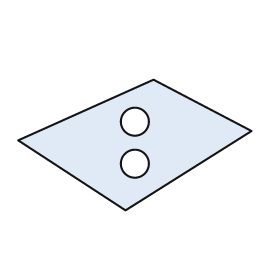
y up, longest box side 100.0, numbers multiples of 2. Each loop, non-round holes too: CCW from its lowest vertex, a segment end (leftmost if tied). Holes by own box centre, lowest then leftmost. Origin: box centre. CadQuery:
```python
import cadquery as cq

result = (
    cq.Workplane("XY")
    .moveTo(-4.0, -28.0)
    .lineTo(50.0, 6.0)
    .lineTo(8.0, 28.0)
    .lineTo(-50.0, 2.0)
    .close()
    .moveTo(0.0, -8.0)
    .circle(6.0)
    .moveTo(0.0, 10.0)
    .circle(6.0)
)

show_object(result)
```